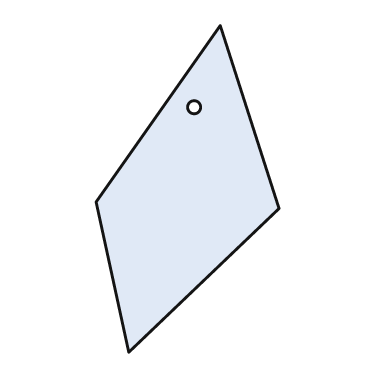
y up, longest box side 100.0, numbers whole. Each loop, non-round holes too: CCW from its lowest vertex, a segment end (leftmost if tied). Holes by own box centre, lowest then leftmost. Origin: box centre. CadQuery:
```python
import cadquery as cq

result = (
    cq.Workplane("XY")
    .moveTo(-18.0, -50.0)
    .lineTo(28.0, -6.0)
    .lineTo(10.0, 50.0)
    .lineTo(-28.0, -4.0)
    .close()
    .moveTo(2.0, 25.0)
    .circle(2.0)
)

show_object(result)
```